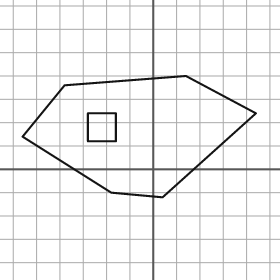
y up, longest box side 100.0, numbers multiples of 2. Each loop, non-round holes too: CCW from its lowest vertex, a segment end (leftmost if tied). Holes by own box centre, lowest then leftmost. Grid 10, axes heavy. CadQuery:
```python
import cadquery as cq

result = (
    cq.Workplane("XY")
    .moveTo(4.0, -12.0)
    .lineTo(44.0, 24.0)
    .lineTo(14.0, 40.0)
    .lineTo(-38.0, 36.0)
    .lineTo(-56.0, 14.0)
    .lineTo(-18.0, -10.0)
    .close()
    .moveTo(-28.0, 12.0)
    .lineTo(-16.0, 12.0)
    .lineTo(-16.0, 24.0)
    .lineTo(-28.0, 24.0)
    .close()
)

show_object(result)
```